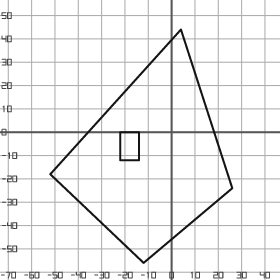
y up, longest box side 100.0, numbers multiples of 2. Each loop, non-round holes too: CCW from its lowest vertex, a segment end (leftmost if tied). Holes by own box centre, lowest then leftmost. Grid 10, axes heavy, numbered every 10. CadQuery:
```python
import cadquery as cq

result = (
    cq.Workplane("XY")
    .moveTo(-12.0, -56.0)
    .lineTo(26.0, -24.0)
    .lineTo(4.0, 44.0)
    .lineTo(-52.0, -18.0)
    .close()
    .moveTo(-22.0, -12.0)
    .lineTo(-14.0, -12.0)
    .lineTo(-14.0, 0.0)
    .lineTo(-22.0, 0.0)
    .close()
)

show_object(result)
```